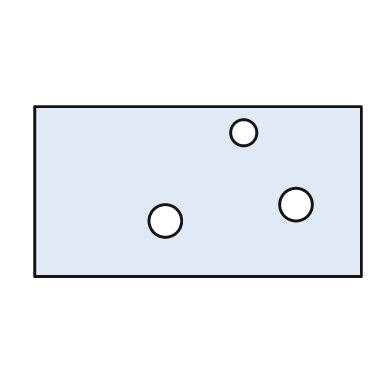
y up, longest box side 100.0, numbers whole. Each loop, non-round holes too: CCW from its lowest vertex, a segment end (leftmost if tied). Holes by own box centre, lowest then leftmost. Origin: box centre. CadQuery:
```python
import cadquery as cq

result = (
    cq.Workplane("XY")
    .moveTo(-50.0, -26.0)
    .lineTo(50.0, -26.0)
    .lineTo(50.0, 26.0)
    .lineTo(-50.0, 26.0)
    .close()
    .moveTo(-10.0, -9.0)
    .circle(5.0)
    .moveTo(30.0, -4.0)
    .circle(5.0)
    .moveTo(14.0, 18.0)
    .circle(4.0)
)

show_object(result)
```